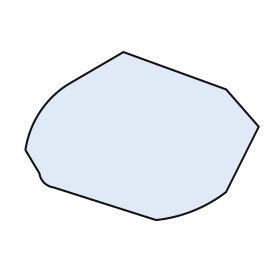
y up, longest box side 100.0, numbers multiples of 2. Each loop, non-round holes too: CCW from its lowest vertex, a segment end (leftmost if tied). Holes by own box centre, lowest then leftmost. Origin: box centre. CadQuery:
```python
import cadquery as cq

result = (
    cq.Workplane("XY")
    .moveTo(6.0, -36.0)
    .threePointArc((22.0, -32.0), (36.0, -24.0))
    .lineTo(50.0, 4.0)
    .lineTo(36.0, 20.0)
    .lineTo(-8.0, 36.0)
    .lineTo(-32.0, 22.0)
    .threePointArc((-44.0, 10.0), (-50.0, -6.0))
    .lineTo(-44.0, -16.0)
    .threePointArc((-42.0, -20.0), (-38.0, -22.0))
    .close()
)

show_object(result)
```